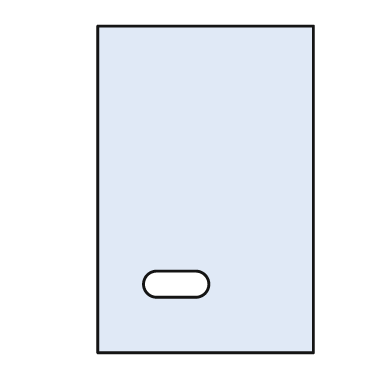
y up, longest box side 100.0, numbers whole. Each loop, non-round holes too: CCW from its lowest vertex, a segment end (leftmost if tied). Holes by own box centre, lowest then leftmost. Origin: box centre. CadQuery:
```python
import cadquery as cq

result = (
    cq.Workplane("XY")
    .moveTo(-33.0, -50.0)
    .lineTo(33.0, -50.0)
    .lineTo(33.0, 50.0)
    .lineTo(-33.0, 50.0)
    .close()
    .moveTo(-15.0, -33.0)
    .lineTo(-3.0, -33.0)
    .threePointArc((1.0, -29.0), (-3.0, -25.0))
    .lineTo(-15.0, -25.0)
    .threePointArc((-19.0, -29.0), (-15.0, -33.0))
    .close()
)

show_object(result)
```